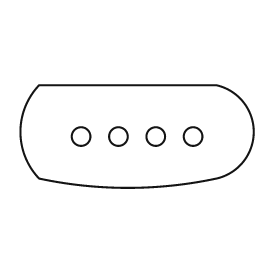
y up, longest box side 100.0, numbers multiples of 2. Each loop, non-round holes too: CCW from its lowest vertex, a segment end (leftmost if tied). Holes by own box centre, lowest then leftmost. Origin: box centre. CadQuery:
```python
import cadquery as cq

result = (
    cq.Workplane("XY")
    .moveTo(-42.0, -18.0)
    .threePointArc((-4.0, -22.0), (34.0, -18.0))
    .threePointArc((50.0, 2.0), (34.0, 22.0))
    .lineTo(-42.0, 22.0)
    .threePointArc((-50.0, 2.0), (-42.0, -18.0))
    .close()
    .moveTo(-24.0, 0.0)
    .circle(4.0)
    .moveTo(-8.0, 0.0)
    .circle(4.0)
    .moveTo(8.0, 0.0)
    .circle(4.0)
    .moveTo(24.0, 0.0)
    .circle(4.0)
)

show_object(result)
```